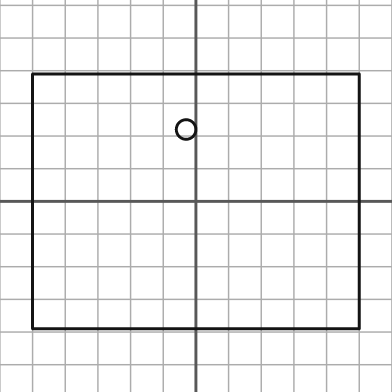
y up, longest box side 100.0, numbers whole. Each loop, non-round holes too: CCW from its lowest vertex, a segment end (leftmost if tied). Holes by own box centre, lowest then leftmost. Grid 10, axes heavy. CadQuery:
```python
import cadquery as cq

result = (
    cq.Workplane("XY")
    .moveTo(-50.0, -39.0)
    .lineTo(50.0, -39.0)
    .lineTo(50.0, 39.0)
    .lineTo(-50.0, 39.0)
    .close()
    .moveTo(-3.0, 22.0)
    .circle(3.0)
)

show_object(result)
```